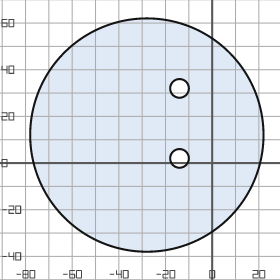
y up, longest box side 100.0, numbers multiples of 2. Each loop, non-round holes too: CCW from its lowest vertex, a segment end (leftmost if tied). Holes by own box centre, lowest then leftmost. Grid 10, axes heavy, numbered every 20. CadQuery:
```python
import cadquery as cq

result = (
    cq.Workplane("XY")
    .moveTo(-28.0, 12.0)
    .circle(50.0)
    .moveTo(-14.0, 2.0)
    .circle(4.0)
    .moveTo(-14.0, 32.0)
    .circle(4.0)
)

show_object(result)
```